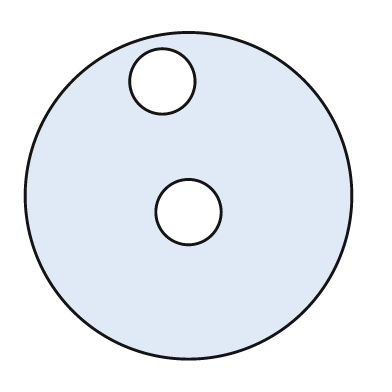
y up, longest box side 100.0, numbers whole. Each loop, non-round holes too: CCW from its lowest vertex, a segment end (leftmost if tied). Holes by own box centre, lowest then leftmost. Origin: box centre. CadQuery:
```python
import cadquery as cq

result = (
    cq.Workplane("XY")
    .moveTo(0.0, 0.0)
    .circle(50.0)
    .moveTo(0.0, -5.0)
    .circle(10.0)
    .moveTo(-8.0, 35.0)
    .circle(10.0)
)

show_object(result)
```